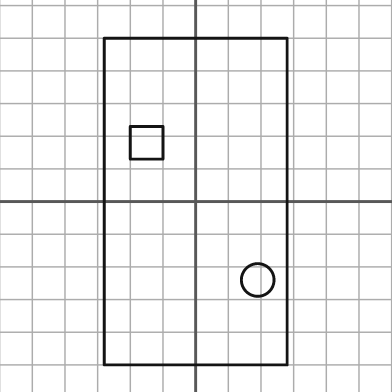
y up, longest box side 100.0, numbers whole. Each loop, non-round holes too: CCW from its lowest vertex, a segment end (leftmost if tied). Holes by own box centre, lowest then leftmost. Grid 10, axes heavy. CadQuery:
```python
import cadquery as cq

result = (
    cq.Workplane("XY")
    .moveTo(-28.0, -50.0)
    .lineTo(28.0, -50.0)
    .lineTo(28.0, 50.0)
    .lineTo(-28.0, 50.0)
    .close()
    .moveTo(19.0, -24.0)
    .circle(5.0)
    .moveTo(-20.0, 13.0)
    .lineTo(-10.0, 13.0)
    .lineTo(-10.0, 23.0)
    .lineTo(-20.0, 23.0)
    .close()
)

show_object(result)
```